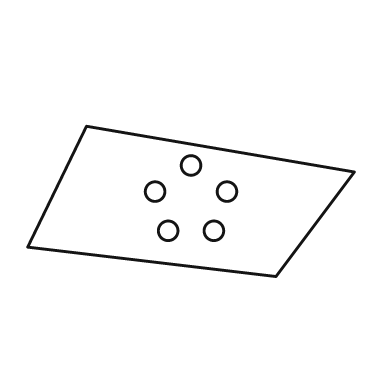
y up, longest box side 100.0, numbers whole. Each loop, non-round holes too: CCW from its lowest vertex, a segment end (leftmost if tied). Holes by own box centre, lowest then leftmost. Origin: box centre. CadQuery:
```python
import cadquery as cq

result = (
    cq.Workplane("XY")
    .moveTo(26.0, -23.0)
    .lineTo(50.0, 9.0)
    .lineTo(-32.0, 23.0)
    .lineTo(-50.0, -14.0)
    .close()
    .moveTo(-7.0, -9.0)
    .circle(3.0)
    .moveTo(7.0, -9.0)
    .circle(3.0)
    .moveTo(-11.0, 3.0)
    .circle(3.0)
    .moveTo(11.0, 3.0)
    .circle(3.0)
    .moveTo(0.0, 11.0)
    .circle(3.0)
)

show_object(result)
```